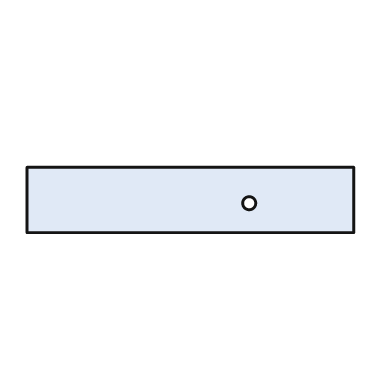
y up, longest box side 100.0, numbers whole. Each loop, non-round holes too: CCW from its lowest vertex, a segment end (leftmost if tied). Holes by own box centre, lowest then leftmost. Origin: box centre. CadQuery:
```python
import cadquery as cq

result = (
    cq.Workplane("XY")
    .moveTo(-50.0, -10.0)
    .lineTo(50.0, -10.0)
    .lineTo(50.0, 10.0)
    .lineTo(-50.0, 10.0)
    .close()
    .moveTo(18.0, -1.0)
    .circle(2.0)
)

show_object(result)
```